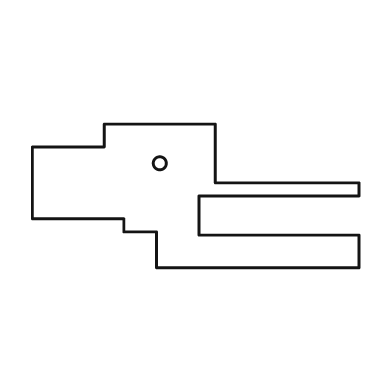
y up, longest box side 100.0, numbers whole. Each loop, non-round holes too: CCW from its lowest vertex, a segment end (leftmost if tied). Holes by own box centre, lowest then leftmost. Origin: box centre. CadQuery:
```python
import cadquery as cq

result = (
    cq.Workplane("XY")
    .moveTo(-12.0, -22.0)
    .lineTo(50.0, -22.0)
    .lineTo(50.0, -12.0)
    .lineTo(1.0, -12.0)
    .lineTo(1.0, 0.0)
    .lineTo(50.0, 0.0)
    .lineTo(50.0, 4.0)
    .lineTo(6.0, 4.0)
    .lineTo(6.0, 22.0)
    .lineTo(-28.0, 22.0)
    .lineTo(-28.0, 15.0)
    .lineTo(-50.0, 15.0)
    .lineTo(-50.0, -7.0)
    .lineTo(-22.0, -7.0)
    .lineTo(-22.0, -11.0)
    .lineTo(-12.0, -11.0)
    .close()
    .moveTo(-11.0, 10.0)
    .circle(2.0)
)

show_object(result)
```